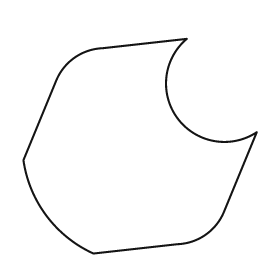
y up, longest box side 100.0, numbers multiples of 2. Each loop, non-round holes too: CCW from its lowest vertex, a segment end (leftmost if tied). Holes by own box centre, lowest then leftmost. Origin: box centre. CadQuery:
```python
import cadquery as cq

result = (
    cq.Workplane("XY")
    .moveTo(-20.0, -46.0)
    .lineTo(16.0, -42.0)
    .threePointArc((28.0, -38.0), (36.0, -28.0))
    .lineTo(50.0, 6.0)
    .threePointArc((16.0, 12.0), (20.0, 46.0))
    .lineTo(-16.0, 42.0)
    .threePointArc((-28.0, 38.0), (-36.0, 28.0))
    .lineTo(-50.0, -6.0)
    .threePointArc((-40.0, -30.0), (-20.0, -46.0))
    .close()
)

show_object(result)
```